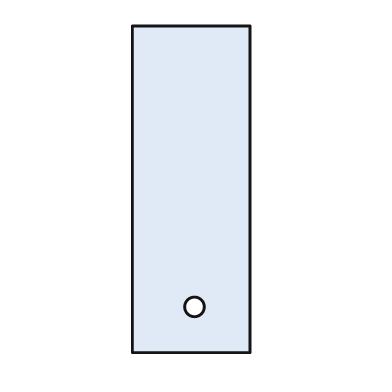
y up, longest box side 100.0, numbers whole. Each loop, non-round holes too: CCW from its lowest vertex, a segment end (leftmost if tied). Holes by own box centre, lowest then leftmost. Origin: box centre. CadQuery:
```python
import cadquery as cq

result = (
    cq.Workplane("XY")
    .moveTo(-18.0, -50.0)
    .lineTo(18.0, -50.0)
    .lineTo(18.0, 50.0)
    .lineTo(-18.0, 50.0)
    .close()
    .moveTo(1.0, -36.0)
    .circle(3.0)
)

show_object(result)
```